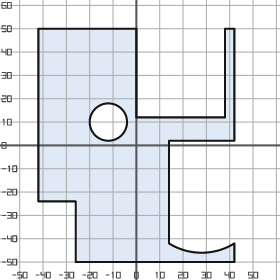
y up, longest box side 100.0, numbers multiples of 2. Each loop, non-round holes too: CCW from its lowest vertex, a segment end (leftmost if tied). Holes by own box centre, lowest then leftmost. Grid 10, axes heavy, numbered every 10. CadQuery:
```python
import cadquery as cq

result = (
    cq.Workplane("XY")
    .moveTo(-26.0, -50.0)
    .lineTo(42.0, -50.0)
    .lineTo(42.0, -42.0)
    .threePointArc((28.0, -46.0), (14.0, -42.0))
    .lineTo(14.0, 2.0)
    .lineTo(42.0, 2.0)
    .lineTo(42.0, 50.0)
    .lineTo(38.0, 50.0)
    .lineTo(38.0, 12.0)
    .lineTo(0.0, 12.0)
    .lineTo(0.0, 50.0)
    .lineTo(-42.0, 50.0)
    .lineTo(-42.0, -24.0)
    .lineTo(-26.0, -24.0)
    .close()
    .moveTo(-12.0, 10.0)
    .circle(8.0)
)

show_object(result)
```